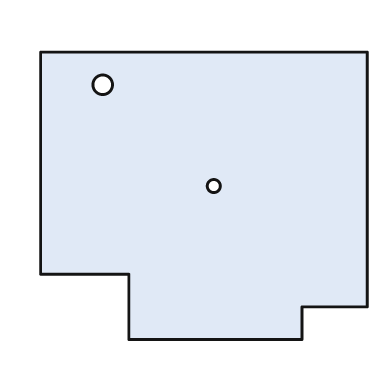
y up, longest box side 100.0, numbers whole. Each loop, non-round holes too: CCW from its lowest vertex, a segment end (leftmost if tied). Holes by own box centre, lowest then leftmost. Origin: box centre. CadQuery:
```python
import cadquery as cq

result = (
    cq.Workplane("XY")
    .moveTo(-23.0, -44.0)
    .lineTo(30.0, -44.0)
    .lineTo(30.0, -34.0)
    .lineTo(50.0, -34.0)
    .lineTo(50.0, 44.0)
    .lineTo(-50.0, 44.0)
    .lineTo(-50.0, -24.0)
    .lineTo(-23.0, -24.0)
    .close()
    .moveTo(3.0, 3.0)
    .circle(2.0)
    .moveTo(-31.0, 34.0)
    .circle(3.0)
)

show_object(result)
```